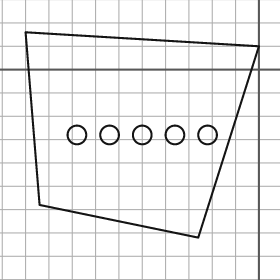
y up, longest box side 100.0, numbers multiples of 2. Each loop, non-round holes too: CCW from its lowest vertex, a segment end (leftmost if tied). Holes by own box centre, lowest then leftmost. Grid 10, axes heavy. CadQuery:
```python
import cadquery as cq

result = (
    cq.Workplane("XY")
    .moveTo(-26.0, -72.0)
    .lineTo(0.0, 10.0)
    .lineTo(-100.0, 16.0)
    .lineTo(-94.0, -58.0)
    .close()
    .moveTo(-78.0, -28.0)
    .circle(4.0)
    .moveTo(-64.0, -28.0)
    .circle(4.0)
    .moveTo(-50.0, -28.0)
    .circle(4.0)
    .moveTo(-36.0, -28.0)
    .circle(4.0)
    .moveTo(-22.0, -28.0)
    .circle(4.0)
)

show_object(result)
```